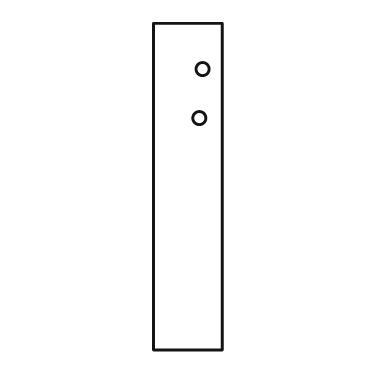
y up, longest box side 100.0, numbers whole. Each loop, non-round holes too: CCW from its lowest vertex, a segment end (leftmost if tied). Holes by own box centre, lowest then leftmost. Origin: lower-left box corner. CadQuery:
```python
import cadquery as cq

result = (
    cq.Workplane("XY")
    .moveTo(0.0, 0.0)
    .lineTo(21.0, 0.0)
    .lineTo(21.0, 100.0)
    .lineTo(0.0, 100.0)
    .close()
    .moveTo(14.0, 71.0)
    .circle(2.0)
    .moveTo(15.0, 86.0)
    .circle(2.0)
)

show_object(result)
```